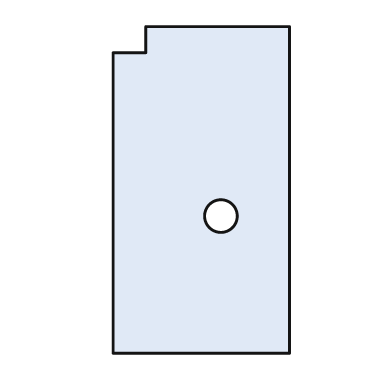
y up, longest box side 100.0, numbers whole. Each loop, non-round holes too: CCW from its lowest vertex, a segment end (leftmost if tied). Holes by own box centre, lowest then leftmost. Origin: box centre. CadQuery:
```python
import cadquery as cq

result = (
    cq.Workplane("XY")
    .moveTo(-27.0, -50.0)
    .lineTo(27.0, -50.0)
    .lineTo(27.0, 50.0)
    .lineTo(-17.0, 50.0)
    .lineTo(-17.0, 42.0)
    .lineTo(-27.0, 42.0)
    .close()
    .moveTo(6.0, -8.0)
    .circle(5.0)
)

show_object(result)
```